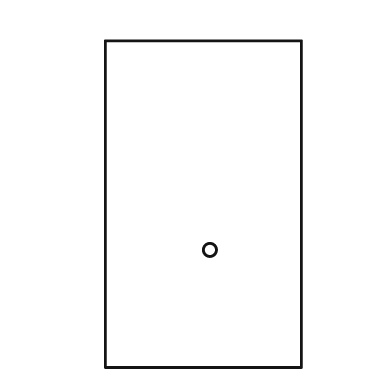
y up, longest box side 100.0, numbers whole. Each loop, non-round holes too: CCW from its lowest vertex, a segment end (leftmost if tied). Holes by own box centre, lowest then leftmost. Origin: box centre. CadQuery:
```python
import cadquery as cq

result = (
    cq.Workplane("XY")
    .moveTo(-30.0, -50.0)
    .lineTo(30.0, -50.0)
    .lineTo(30.0, 50.0)
    .lineTo(-30.0, 50.0)
    .close()
    .moveTo(2.0, -14.0)
    .circle(2.0)
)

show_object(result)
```